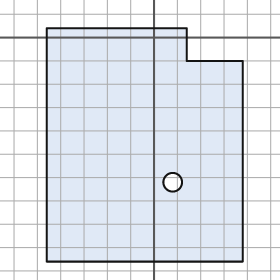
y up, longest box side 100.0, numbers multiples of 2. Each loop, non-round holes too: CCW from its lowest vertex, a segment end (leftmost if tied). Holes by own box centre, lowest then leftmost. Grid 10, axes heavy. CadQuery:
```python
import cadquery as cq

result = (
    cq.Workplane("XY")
    .moveTo(-46.0, -96.0)
    .lineTo(38.0, -96.0)
    .lineTo(38.0, -10.0)
    .lineTo(14.0, -10.0)
    .lineTo(14.0, 4.0)
    .lineTo(-46.0, 4.0)
    .close()
    .moveTo(8.0, -62.0)
    .circle(4.0)
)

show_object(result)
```